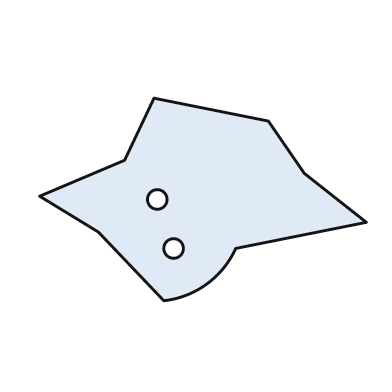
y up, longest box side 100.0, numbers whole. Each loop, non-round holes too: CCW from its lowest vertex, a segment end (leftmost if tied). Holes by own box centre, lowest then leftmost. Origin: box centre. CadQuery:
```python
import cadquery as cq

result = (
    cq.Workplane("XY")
    .moveTo(-12.0, -31.0)
    .threePointArc((1.0, -26.0), (10.0, -15.0))
    .lineTo(50.0, -7.0)
    .lineTo(31.0, 8.0)
    .lineTo(20.0, 24.0)
    .lineTo(-15.0, 31.0)
    .lineTo(-24.0, 12.0)
    .lineTo(-50.0, 1.0)
    .lineTo(-32.0, -10.0)
    .close()
    .moveTo(-9.0, -15.0)
    .circle(3.0)
    .moveTo(-14.0, 0.0)
    .circle(3.0)
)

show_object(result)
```